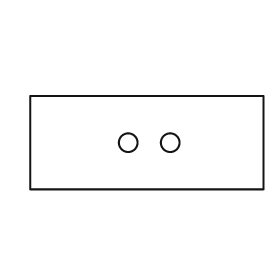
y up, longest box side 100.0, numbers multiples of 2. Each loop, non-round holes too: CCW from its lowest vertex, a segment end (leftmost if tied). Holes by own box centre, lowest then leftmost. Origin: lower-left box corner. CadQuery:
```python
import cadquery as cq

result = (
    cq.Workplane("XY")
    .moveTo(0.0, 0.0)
    .lineTo(100.0, 0.0)
    .lineTo(100.0, 40.0)
    .lineTo(0.0, 40.0)
    .close()
    .moveTo(42.0, 20.0)
    .circle(4.0)
    .moveTo(60.0, 20.0)
    .circle(4.0)
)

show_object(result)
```